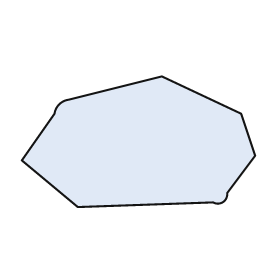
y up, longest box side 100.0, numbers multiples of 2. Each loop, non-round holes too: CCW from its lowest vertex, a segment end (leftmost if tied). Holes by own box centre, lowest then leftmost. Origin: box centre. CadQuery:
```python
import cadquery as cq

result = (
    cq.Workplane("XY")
    .moveTo(-26.0, -28.0)
    .lineTo(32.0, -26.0)
    .threePointArc((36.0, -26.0), (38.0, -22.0))
    .lineTo(50.0, -6.0)
    .lineTo(44.0, 12.0)
    .lineTo(10.0, 28.0)
    .lineTo(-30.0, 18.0)
    .threePointArc((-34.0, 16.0), (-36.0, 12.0))
    .lineTo(-50.0, -8.0)
    .close()
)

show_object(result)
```